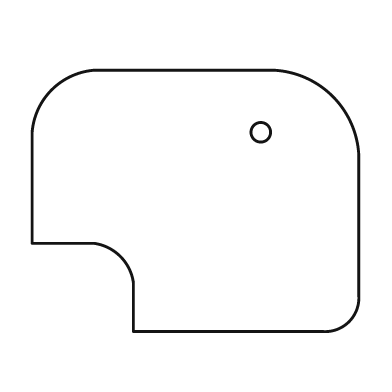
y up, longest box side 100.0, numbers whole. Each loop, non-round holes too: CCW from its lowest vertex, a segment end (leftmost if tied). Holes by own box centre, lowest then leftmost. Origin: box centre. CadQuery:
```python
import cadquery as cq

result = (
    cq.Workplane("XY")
    .moveTo(-19.0, -40.0)
    .lineTo(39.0, -40.0)
    .threePointArc((47.0, -37.0), (50.0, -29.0))
    .lineTo(50.0, 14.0)
    .threePointArc((42.0, 32.0), (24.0, 40.0))
    .lineTo(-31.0, 40.0)
    .threePointArc((-44.0, 34.0), (-50.0, 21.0))
    .lineTo(-50.0, -13.0)
    .lineTo(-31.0, -13.0)
    .threePointArc((-23.0, -17.0), (-19.0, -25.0))
    .close()
    .moveTo(20.0, 21.0)
    .circle(3.0)
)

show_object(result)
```